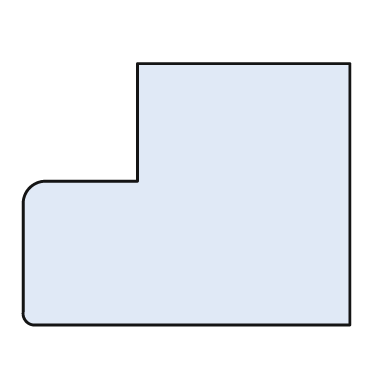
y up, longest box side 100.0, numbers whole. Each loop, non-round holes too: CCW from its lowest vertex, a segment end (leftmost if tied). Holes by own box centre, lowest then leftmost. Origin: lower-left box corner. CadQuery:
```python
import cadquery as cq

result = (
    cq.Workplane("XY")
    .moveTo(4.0, 0.0)
    .lineTo(100.0, 0.0)
    .lineTo(100.0, 80.0)
    .lineTo(35.0, 80.0)
    .lineTo(35.0, 44.0)
    .lineTo(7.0, 44.0)
    .threePointArc((2.0, 42.0), (0.0, 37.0))
    .lineTo(0.0, 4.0)
    .threePointArc((1.0, 1.0), (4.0, 0.0))
    .close()
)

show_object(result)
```